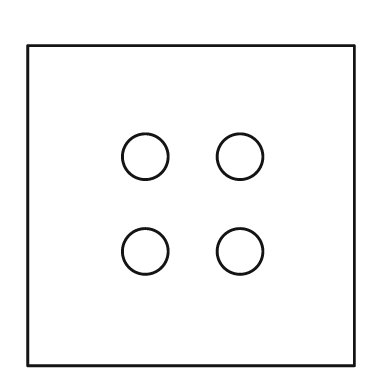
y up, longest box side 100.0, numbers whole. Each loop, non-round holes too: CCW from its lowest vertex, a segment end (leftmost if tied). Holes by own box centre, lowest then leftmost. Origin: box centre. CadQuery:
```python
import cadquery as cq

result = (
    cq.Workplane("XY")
    .moveTo(-50.0, -49.0)
    .lineTo(50.0, -49.0)
    .lineTo(50.0, 49.0)
    .lineTo(-50.0, 49.0)
    .close()
    .moveTo(-14.0, -14.0)
    .circle(7.0)
    .moveTo(15.0, -14.0)
    .circle(7.0)
    .moveTo(-14.0, 15.0)
    .circle(7.0)
    .moveTo(15.0, 15.0)
    .circle(7.0)
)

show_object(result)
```